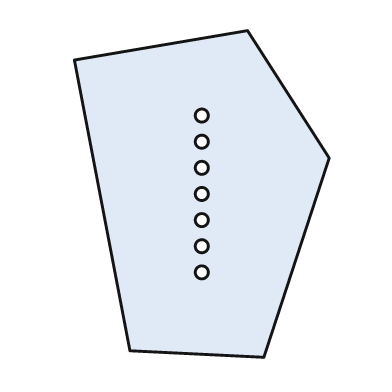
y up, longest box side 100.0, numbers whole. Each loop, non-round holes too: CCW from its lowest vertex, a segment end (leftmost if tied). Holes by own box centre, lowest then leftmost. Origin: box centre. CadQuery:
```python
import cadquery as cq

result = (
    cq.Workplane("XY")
    .moveTo(19.0, -50.0)
    .lineTo(39.0, 11.0)
    .lineTo(14.0, 50.0)
    .lineTo(-39.0, 41.0)
    .lineTo(-22.0, -48.0)
    .close()
    .moveTo(0.0, -24.0)
    .circle(2.0)
    .moveTo(0.0, -16.0)
    .circle(2.0)
    .moveTo(0.0, -8.0)
    .circle(2.0)
    .moveTo(0.0, 0.0)
    .circle(2.0)
    .moveTo(0.0, 8.0)
    .circle(2.0)
    .moveTo(0.0, 16.0)
    .circle(2.0)
    .moveTo(0.0, 24.0)
    .circle(2.0)
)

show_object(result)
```